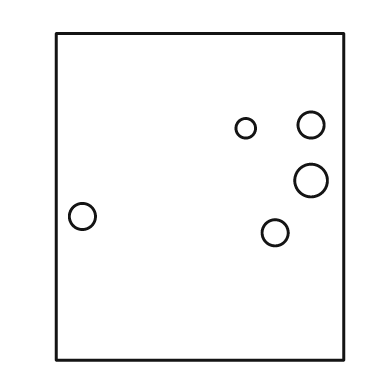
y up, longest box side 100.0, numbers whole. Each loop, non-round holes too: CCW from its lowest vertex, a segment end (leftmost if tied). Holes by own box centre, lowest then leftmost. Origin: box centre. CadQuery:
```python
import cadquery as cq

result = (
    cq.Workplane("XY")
    .moveTo(-44.0, -50.0)
    .lineTo(44.0, -50.0)
    .lineTo(44.0, 50.0)
    .lineTo(-44.0, 50.0)
    .close()
    .moveTo(23.0, -11.0)
    .circle(4.0)
    .moveTo(-36.0, -6.0)
    .circle(4.0)
    .moveTo(34.0, 5.0)
    .circle(5.0)
    .moveTo(14.0, 21.0)
    .circle(3.0)
    .moveTo(34.0, 22.0)
    .circle(4.0)
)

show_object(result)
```